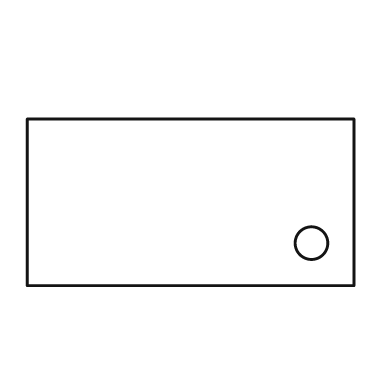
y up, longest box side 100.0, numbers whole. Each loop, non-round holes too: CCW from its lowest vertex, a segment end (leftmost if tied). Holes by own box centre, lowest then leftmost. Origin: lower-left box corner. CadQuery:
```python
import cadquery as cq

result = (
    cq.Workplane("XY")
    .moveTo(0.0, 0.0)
    .lineTo(100.0, 0.0)
    .lineTo(100.0, 51.0)
    .lineTo(0.0, 51.0)
    .close()
    .moveTo(87.0, 13.0)
    .circle(5.0)
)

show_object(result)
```